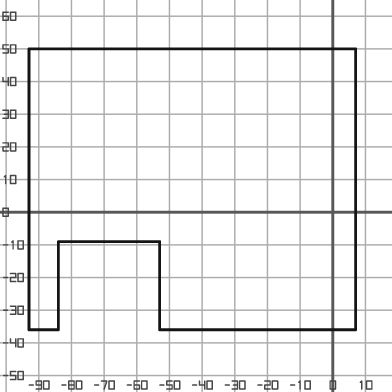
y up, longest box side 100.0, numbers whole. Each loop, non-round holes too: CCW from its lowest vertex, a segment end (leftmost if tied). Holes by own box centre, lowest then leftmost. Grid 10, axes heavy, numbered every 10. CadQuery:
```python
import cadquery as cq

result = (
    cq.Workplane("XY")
    .moveTo(-93.0, -36.0)
    .lineTo(-84.0, -36.0)
    .lineTo(-84.0, -9.0)
    .lineTo(-53.0, -9.0)
    .lineTo(-53.0, -36.0)
    .lineTo(7.0, -36.0)
    .lineTo(7.0, 50.0)
    .lineTo(-93.0, 50.0)
    .close()
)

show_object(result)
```